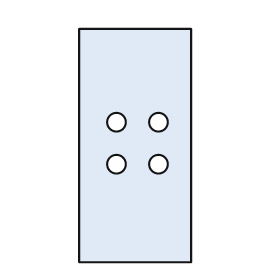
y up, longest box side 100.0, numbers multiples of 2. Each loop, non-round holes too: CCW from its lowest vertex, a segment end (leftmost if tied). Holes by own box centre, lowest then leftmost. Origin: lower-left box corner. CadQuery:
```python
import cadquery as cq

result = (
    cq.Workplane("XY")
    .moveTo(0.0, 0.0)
    .lineTo(48.0, 0.0)
    .lineTo(48.0, 100.0)
    .lineTo(0.0, 100.0)
    .close()
    .moveTo(16.0, 42.0)
    .circle(4.0)
    .moveTo(34.0, 42.0)
    .circle(4.0)
    .moveTo(16.0, 60.0)
    .circle(4.0)
    .moveTo(34.0, 60.0)
    .circle(4.0)
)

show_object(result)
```